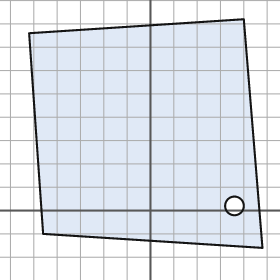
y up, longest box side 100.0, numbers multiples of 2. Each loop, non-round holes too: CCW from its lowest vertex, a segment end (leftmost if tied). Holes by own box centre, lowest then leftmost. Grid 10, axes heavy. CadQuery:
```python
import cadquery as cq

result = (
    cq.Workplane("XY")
    .moveTo(48.0, -16.0)
    .lineTo(40.0, 82.0)
    .lineTo(-52.0, 76.0)
    .lineTo(-46.0, -10.0)
    .close()
    .moveTo(36.0, 2.0)
    .circle(4.0)
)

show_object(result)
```